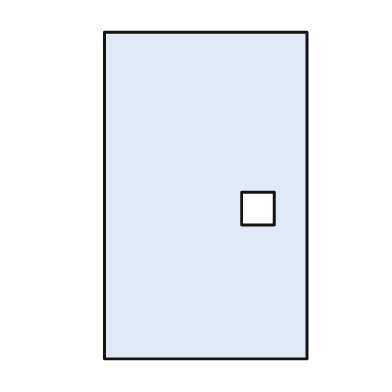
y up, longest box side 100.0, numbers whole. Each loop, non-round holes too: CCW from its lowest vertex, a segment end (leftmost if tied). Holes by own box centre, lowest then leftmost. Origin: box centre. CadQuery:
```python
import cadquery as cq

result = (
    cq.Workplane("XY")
    .moveTo(-31.0, -50.0)
    .lineTo(31.0, -50.0)
    .lineTo(31.0, 50.0)
    .lineTo(-31.0, 50.0)
    .close()
    .moveTo(11.0, -9.0)
    .lineTo(21.0, -9.0)
    .lineTo(21.0, 1.0)
    .lineTo(11.0, 1.0)
    .close()
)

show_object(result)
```